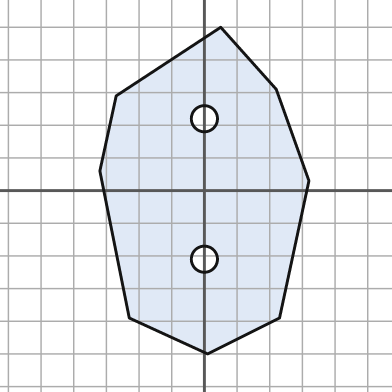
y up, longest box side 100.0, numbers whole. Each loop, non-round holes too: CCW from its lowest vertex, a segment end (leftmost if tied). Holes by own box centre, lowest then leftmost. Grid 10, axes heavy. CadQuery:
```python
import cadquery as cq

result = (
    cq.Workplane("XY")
    .moveTo(1.0, -50.0)
    .lineTo(23.0, -39.0)
    .lineTo(32.0, 3.0)
    .lineTo(22.0, 31.0)
    .lineTo(5.0, 50.0)
    .lineTo(-27.0, 29.0)
    .lineTo(-32.0, 6.0)
    .lineTo(-23.0, -39.0)
    .close()
    .moveTo(0.0, -21.0)
    .circle(4.0)
    .moveTo(0.0, 22.0)
    .circle(4.0)
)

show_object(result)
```